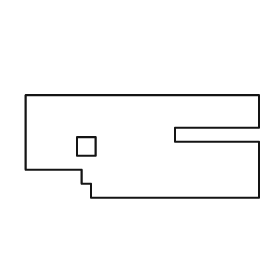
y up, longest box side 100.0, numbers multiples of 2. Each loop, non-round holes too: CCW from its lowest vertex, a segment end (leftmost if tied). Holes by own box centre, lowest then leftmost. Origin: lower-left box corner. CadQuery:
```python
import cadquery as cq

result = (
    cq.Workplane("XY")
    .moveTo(28.0, 0.0)
    .lineTo(100.0, 0.0)
    .lineTo(100.0, 24.0)
    .lineTo(64.0, 24.0)
    .lineTo(64.0, 30.0)
    .lineTo(100.0, 30.0)
    .lineTo(100.0, 44.0)
    .lineTo(0.0, 44.0)
    .lineTo(0.0, 12.0)
    .lineTo(24.0, 12.0)
    .lineTo(24.0, 6.0)
    .lineTo(28.0, 6.0)
    .close()
    .moveTo(22.0, 18.0)
    .lineTo(30.0, 18.0)
    .lineTo(30.0, 26.0)
    .lineTo(22.0, 26.0)
    .close()
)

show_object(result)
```